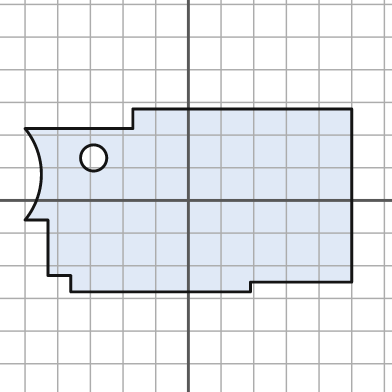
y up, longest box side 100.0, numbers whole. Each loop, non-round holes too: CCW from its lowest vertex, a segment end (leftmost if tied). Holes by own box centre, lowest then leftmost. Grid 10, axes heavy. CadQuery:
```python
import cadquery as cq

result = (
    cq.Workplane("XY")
    .moveTo(-36.0, -28.0)
    .lineTo(19.0, -28.0)
    .lineTo(19.0, -25.0)
    .lineTo(50.0, -25.0)
    .lineTo(50.0, 28.0)
    .lineTo(-17.0, 28.0)
    .lineTo(-17.0, 22.0)
    .lineTo(-50.0, 22.0)
    .threePointArc((-45.0, 8.0), (-50.0, -6.0))
    .lineTo(-43.0, -6.0)
    .lineTo(-43.0, -23.0)
    .lineTo(-36.0, -23.0)
    .close()
    .moveTo(-29.0, 13.0)
    .circle(4.0)
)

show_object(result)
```